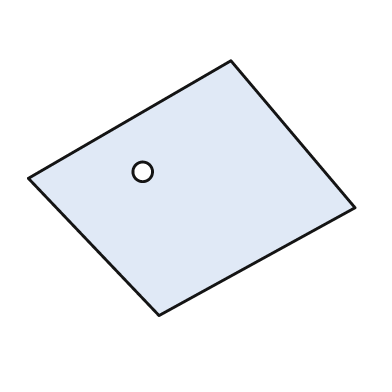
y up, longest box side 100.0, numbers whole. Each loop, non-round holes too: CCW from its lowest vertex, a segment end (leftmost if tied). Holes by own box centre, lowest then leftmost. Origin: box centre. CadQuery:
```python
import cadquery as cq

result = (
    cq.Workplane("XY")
    .moveTo(-10.0, -39.0)
    .lineTo(50.0, -6.0)
    .lineTo(12.0, 39.0)
    .lineTo(-50.0, 3.0)
    .close()
    .moveTo(-15.0, 5.0)
    .circle(3.0)
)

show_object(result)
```